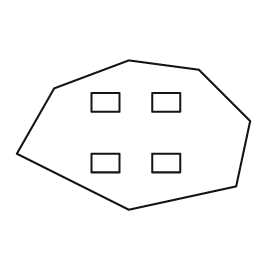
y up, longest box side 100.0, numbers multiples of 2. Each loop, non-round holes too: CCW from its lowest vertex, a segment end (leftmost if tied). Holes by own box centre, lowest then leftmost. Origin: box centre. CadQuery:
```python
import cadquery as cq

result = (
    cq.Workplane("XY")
    .moveTo(-2.0, -32.0)
    .lineTo(44.0, -22.0)
    .lineTo(50.0, 6.0)
    .lineTo(28.0, 28.0)
    .lineTo(-2.0, 32.0)
    .lineTo(-34.0, 20.0)
    .lineTo(-50.0, -8.0)
    .close()
    .moveTo(-18.0, -16.0)
    .lineTo(-6.0, -16.0)
    .lineTo(-6.0, -8.0)
    .lineTo(-18.0, -8.0)
    .close()
    .moveTo(8.0, -16.0)
    .lineTo(20.0, -16.0)
    .lineTo(20.0, -8.0)
    .lineTo(8.0, -8.0)
    .close()
    .moveTo(-18.0, 10.0)
    .lineTo(-6.0, 10.0)
    .lineTo(-6.0, 18.0)
    .lineTo(-18.0, 18.0)
    .close()
    .moveTo(8.0, 10.0)
    .lineTo(20.0, 10.0)
    .lineTo(20.0, 18.0)
    .lineTo(8.0, 18.0)
    .close()
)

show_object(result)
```